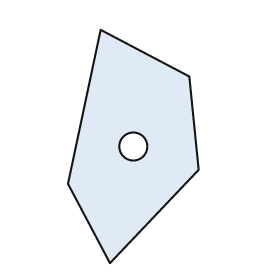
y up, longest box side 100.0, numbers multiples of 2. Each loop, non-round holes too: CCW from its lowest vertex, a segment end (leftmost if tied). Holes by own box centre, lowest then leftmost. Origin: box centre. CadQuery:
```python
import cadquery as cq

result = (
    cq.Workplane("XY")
    .moveTo(-10.0, -50.0)
    .lineTo(28.0, -10.0)
    .lineTo(24.0, 30.0)
    .lineTo(-14.0, 50.0)
    .lineTo(-28.0, -16.0)
    .close()
    .moveTo(0.0, 0.0)
    .circle(6.0)
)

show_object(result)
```